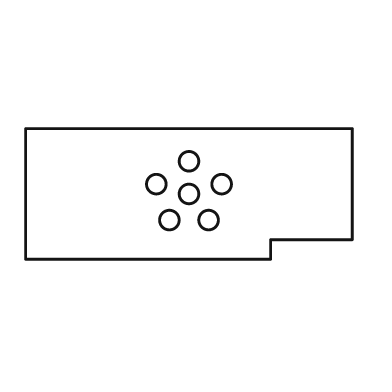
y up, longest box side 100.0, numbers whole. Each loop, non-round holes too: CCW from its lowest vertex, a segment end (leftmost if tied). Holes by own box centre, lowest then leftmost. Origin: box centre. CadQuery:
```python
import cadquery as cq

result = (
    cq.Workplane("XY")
    .moveTo(-50.0, -20.0)
    .lineTo(25.0, -20.0)
    .lineTo(25.0, -14.0)
    .lineTo(50.0, -14.0)
    .lineTo(50.0, 20.0)
    .lineTo(-50.0, 20.0)
    .close()
    .moveTo(-6.0, -8.0)
    .circle(3.0)
    .moveTo(6.0, -8.0)
    .circle(3.0)
    .moveTo(0.0, 0.0)
    .circle(3.0)
    .moveTo(-10.0, 3.0)
    .circle(3.0)
    .moveTo(10.0, 3.0)
    .circle(3.0)
    .moveTo(0.0, 10.0)
    .circle(3.0)
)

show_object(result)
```